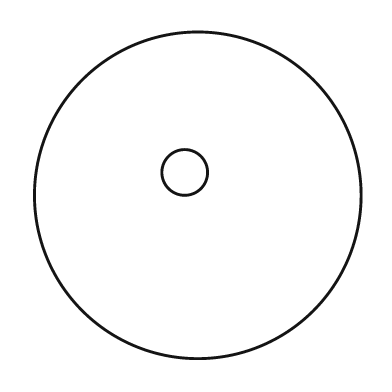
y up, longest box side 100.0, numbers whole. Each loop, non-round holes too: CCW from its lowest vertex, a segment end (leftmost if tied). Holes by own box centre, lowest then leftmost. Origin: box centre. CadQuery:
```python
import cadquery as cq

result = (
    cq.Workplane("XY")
    .moveTo(0.0, 0.0)
    .circle(50.0)
    .moveTo(-4.0, 7.0)
    .circle(7.0)
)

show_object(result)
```